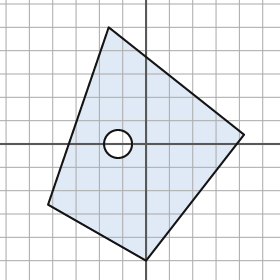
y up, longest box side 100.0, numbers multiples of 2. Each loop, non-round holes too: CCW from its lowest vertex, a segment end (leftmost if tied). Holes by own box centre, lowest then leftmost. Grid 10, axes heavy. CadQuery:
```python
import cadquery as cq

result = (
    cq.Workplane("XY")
    .moveTo(0.0, -50.0)
    .lineTo(42.0, 4.0)
    .lineTo(-16.0, 50.0)
    .lineTo(-42.0, -26.0)
    .close()
    .moveTo(-12.0, 0.0)
    .circle(6.0)
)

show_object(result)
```